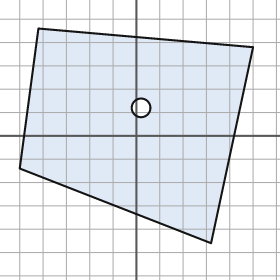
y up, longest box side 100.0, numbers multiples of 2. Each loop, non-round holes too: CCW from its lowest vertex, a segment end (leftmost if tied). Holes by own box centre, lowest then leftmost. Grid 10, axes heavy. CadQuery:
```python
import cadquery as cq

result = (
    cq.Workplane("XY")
    .moveTo(32.0, -46.0)
    .lineTo(50.0, 38.0)
    .lineTo(-42.0, 46.0)
    .lineTo(-50.0, -14.0)
    .close()
    .moveTo(2.0, 12.0)
    .circle(4.0)
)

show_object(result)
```